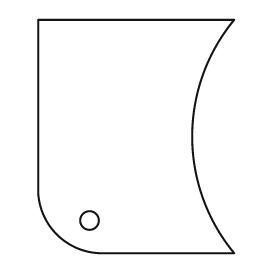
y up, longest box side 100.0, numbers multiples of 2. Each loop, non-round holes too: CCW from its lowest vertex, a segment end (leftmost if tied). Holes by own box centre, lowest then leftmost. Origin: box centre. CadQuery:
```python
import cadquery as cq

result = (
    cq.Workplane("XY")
    .moveTo(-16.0, -50.0)
    .lineTo(42.0, -50.0)
    .threePointArc((24.0, 0.0), (42.0, 50.0))
    .lineTo(-42.0, 50.0)
    .lineTo(-42.0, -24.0)
    .threePointArc((-34.0, -42.0), (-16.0, -50.0))
    .close()
    .moveTo(-20.0, -36.0)
    .circle(4.0)
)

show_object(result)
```